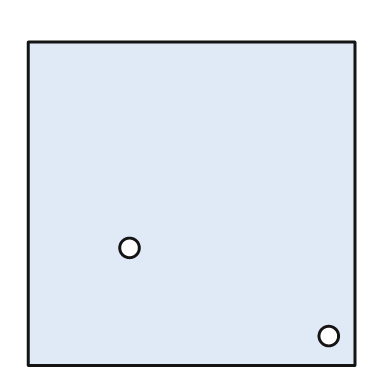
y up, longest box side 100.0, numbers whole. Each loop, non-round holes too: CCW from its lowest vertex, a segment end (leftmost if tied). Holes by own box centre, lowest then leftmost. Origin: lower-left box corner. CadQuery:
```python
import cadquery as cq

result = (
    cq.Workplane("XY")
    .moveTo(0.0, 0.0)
    .lineTo(100.0, 0.0)
    .lineTo(100.0, 99.0)
    .lineTo(0.0, 99.0)
    .close()
    .moveTo(92.0, 9.0)
    .circle(3.0)
    .moveTo(31.0, 36.0)
    .circle(3.0)
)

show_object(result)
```